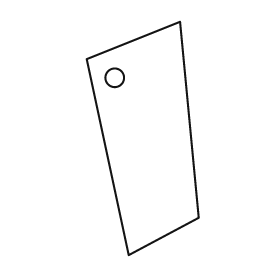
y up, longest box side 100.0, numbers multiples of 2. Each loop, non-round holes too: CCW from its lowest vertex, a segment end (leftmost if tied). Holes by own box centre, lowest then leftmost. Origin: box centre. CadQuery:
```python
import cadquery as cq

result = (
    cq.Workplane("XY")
    .moveTo(-6.0, -50.0)
    .lineTo(24.0, -34.0)
    .lineTo(16.0, 50.0)
    .lineTo(-24.0, 34.0)
    .close()
    .moveTo(-12.0, 26.0)
    .circle(4.0)
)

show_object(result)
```